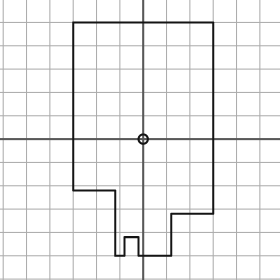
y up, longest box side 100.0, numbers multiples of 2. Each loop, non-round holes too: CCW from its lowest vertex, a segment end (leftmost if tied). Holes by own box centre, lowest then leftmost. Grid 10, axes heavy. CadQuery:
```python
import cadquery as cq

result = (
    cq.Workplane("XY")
    .moveTo(-12.0, -50.0)
    .lineTo(-8.0, -50.0)
    .lineTo(-8.0, -42.0)
    .lineTo(-2.0, -42.0)
    .lineTo(-2.0, -50.0)
    .lineTo(12.0, -50.0)
    .lineTo(12.0, -32.0)
    .lineTo(30.0, -32.0)
    .lineTo(30.0, 50.0)
    .lineTo(-30.0, 50.0)
    .lineTo(-30.0, -22.0)
    .lineTo(-12.0, -22.0)
    .close()
    .moveTo(0.0, 0.0)
    .circle(2.0)
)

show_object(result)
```